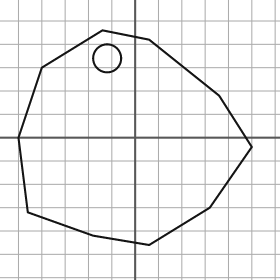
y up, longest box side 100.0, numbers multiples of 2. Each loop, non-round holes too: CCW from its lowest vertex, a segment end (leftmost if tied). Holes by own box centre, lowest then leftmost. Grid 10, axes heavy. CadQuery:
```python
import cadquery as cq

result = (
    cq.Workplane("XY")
    .moveTo(6.0, -46.0)
    .lineTo(32.0, -30.0)
    .lineTo(50.0, -4.0)
    .lineTo(36.0, 18.0)
    .lineTo(6.0, 42.0)
    .lineTo(-14.0, 46.0)
    .lineTo(-40.0, 30.0)
    .lineTo(-50.0, 0.0)
    .lineTo(-46.0, -32.0)
    .lineTo(-18.0, -42.0)
    .close()
    .moveTo(-12.0, 34.0)
    .circle(6.0)
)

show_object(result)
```